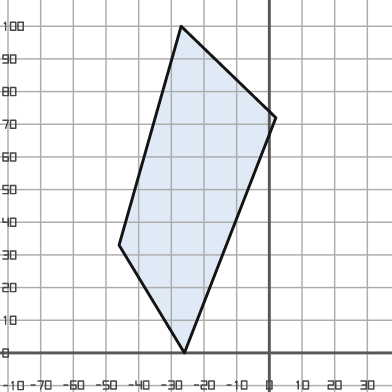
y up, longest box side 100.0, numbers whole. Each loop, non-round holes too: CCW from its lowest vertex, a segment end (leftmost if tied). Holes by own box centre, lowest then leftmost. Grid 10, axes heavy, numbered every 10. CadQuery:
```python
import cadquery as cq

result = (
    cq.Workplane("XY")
    .moveTo(-26.0, 0.0)
    .lineTo(2.0, 72.0)
    .lineTo(-27.0, 100.0)
    .lineTo(-46.0, 33.0)
    .close()
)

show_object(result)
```